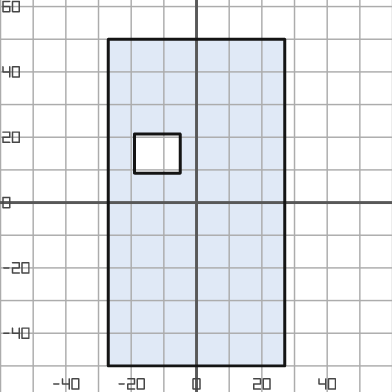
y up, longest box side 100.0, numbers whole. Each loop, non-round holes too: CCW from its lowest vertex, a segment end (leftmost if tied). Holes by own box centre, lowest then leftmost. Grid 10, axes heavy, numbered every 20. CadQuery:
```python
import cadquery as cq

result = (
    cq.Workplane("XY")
    .moveTo(-27.0, -50.0)
    .lineTo(27.0, -50.0)
    .lineTo(27.0, 50.0)
    .lineTo(-27.0, 50.0)
    .close()
    .moveTo(-19.0, 9.0)
    .lineTo(-5.0, 9.0)
    .lineTo(-5.0, 21.0)
    .lineTo(-19.0, 21.0)
    .close()
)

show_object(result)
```